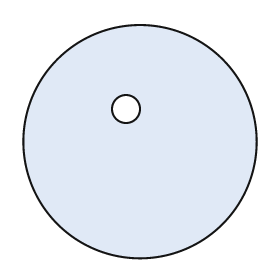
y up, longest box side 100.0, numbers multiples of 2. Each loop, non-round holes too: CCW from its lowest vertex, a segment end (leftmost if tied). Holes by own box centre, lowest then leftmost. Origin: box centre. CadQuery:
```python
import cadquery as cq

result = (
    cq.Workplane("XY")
    .moveTo(0.0, 0.0)
    .circle(50.0)
    .moveTo(-6.0, 14.0)
    .circle(6.0)
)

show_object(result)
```